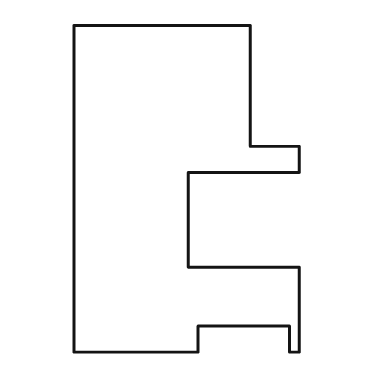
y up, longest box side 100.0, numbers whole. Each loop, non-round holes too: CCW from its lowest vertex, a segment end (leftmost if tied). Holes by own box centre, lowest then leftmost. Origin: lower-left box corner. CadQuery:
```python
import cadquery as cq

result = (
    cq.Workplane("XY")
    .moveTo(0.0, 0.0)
    .lineTo(38.0, 0.0)
    .lineTo(38.0, 8.0)
    .lineTo(66.0, 8.0)
    .lineTo(66.0, 0.0)
    .lineTo(69.0, 0.0)
    .lineTo(69.0, 26.0)
    .lineTo(35.0, 26.0)
    .lineTo(35.0, 55.0)
    .lineTo(69.0, 55.0)
    .lineTo(69.0, 63.0)
    .lineTo(54.0, 63.0)
    .lineTo(54.0, 100.0)
    .lineTo(0.0, 100.0)
    .close()
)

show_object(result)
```